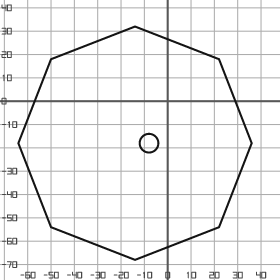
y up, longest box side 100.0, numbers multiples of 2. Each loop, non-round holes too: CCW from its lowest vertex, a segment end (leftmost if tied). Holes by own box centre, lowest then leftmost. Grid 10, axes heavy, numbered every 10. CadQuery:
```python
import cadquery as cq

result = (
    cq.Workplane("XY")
    .moveTo(-14.0, -68.0)
    .lineTo(22.0, -54.0)
    .lineTo(36.0, -18.0)
    .lineTo(22.0, 18.0)
    .lineTo(-14.0, 32.0)
    .lineTo(-50.0, 18.0)
    .lineTo(-64.0, -18.0)
    .lineTo(-50.0, -54.0)
    .close()
    .moveTo(-8.0, -18.0)
    .circle(4.0)
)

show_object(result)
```